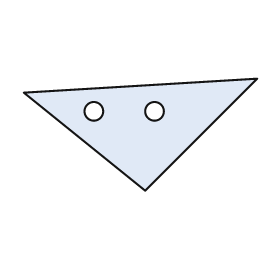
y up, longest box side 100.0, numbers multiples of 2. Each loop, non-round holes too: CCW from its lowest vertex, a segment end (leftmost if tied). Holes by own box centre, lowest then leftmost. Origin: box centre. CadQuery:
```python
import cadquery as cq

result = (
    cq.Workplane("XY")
    .moveTo(2.0, -24.0)
    .lineTo(50.0, 24.0)
    .lineTo(-50.0, 18.0)
    .close()
    .moveTo(-20.0, 10.0)
    .circle(4.0)
    .moveTo(6.0, 10.0)
    .circle(4.0)
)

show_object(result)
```